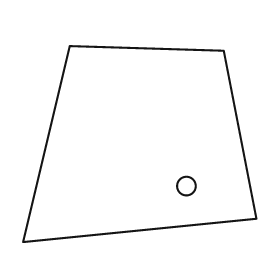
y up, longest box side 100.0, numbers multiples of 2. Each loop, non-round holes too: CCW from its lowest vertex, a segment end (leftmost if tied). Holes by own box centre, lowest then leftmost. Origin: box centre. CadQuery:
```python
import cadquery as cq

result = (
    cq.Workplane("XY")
    .moveTo(-50.0, -42.0)
    .lineTo(50.0, -32.0)
    .lineTo(36.0, 40.0)
    .lineTo(-30.0, 42.0)
    .close()
    .moveTo(20.0, -18.0)
    .circle(4.0)
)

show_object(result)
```